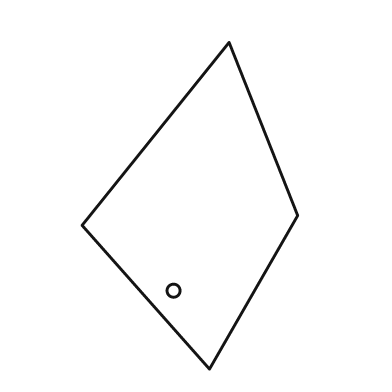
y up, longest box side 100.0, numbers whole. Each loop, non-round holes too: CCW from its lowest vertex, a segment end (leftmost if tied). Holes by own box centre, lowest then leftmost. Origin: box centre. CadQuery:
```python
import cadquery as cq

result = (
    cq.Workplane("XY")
    .moveTo(6.0, -50.0)
    .lineTo(33.0, -3.0)
    .lineTo(12.0, 50.0)
    .lineTo(-33.0, -6.0)
    .close()
    .moveTo(-5.0, -26.0)
    .circle(2.0)
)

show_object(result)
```